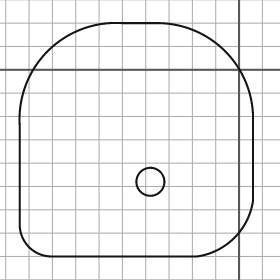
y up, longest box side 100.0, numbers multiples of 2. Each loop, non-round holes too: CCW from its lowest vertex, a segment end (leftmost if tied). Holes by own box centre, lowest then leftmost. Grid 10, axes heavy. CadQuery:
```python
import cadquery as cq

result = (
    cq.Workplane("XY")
    .moveTo(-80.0, -80.0)
    .lineTo(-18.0, -80.0)
    .threePointArc((-2.0, -72.0), (6.0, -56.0))
    .lineTo(6.0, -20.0)
    .threePointArc((-6.0, 8.0), (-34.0, 20.0))
    .lineTo(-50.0, 20.0)
    .threePointArc((-82.0, 8.0), (-94.0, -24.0))
    .lineTo(-94.0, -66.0)
    .threePointArc((-90.0, -76.0), (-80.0, -80.0))
    .close()
    .moveTo(-38.0, -48.0)
    .circle(6.0)
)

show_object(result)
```